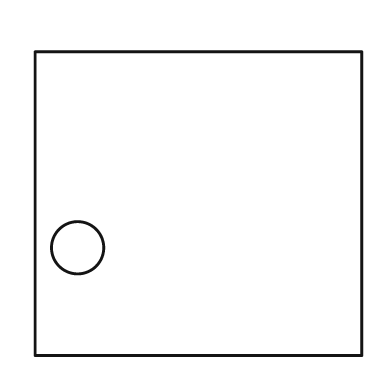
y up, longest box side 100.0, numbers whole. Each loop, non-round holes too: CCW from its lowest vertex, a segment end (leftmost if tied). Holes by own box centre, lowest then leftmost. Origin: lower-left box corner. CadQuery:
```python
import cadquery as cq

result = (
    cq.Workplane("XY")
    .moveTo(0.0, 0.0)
    .lineTo(100.0, 0.0)
    .lineTo(100.0, 93.0)
    .lineTo(0.0, 93.0)
    .close()
    .moveTo(13.0, 33.0)
    .circle(8.0)
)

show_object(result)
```